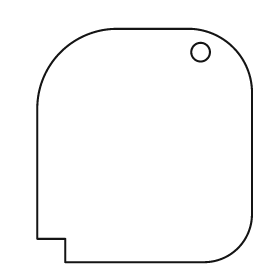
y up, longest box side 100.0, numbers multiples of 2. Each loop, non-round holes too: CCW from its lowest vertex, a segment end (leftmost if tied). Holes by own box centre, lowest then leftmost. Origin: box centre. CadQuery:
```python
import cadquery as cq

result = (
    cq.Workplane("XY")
    .moveTo(-34.0, -50.0)
    .lineTo(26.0, -50.0)
    .threePointArc((40.0, -44.0), (46.0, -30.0))
    .lineTo(46.0, 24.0)
    .threePointArc((38.0, 42.0), (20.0, 50.0))
    .lineTo(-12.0, 50.0)
    .threePointArc((-36.0, 40.0), (-46.0, 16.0))
    .lineTo(-46.0, -40.0)
    .lineTo(-34.0, -40.0)
    .close()
    .moveTo(24.0, 40.0)
    .circle(4.0)
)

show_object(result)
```